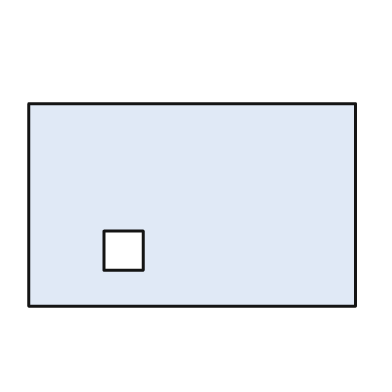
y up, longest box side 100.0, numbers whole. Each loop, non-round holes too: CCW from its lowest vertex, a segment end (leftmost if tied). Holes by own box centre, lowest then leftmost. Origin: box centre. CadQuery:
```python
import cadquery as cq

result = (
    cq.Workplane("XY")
    .moveTo(-50.0, -31.0)
    .lineTo(50.0, -31.0)
    .lineTo(50.0, 31.0)
    .lineTo(-50.0, 31.0)
    .close()
    .moveTo(-27.0, -20.0)
    .lineTo(-15.0, -20.0)
    .lineTo(-15.0, -8.0)
    .lineTo(-27.0, -8.0)
    .close()
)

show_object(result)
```